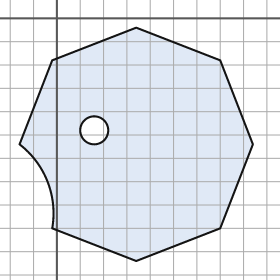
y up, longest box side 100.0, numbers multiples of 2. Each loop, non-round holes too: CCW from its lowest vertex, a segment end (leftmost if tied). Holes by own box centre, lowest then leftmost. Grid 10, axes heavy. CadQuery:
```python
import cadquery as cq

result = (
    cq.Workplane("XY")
    .moveTo(34.0, -104.0)
    .lineTo(70.0, -90.0)
    .lineTo(84.0, -54.0)
    .lineTo(70.0, -18.0)
    .lineTo(34.0, -4.0)
    .lineTo(-2.0, -18.0)
    .lineTo(-16.0, -54.0)
    .threePointArc((-4.0, -70.0), (-2.0, -90.0))
    .close()
    .moveTo(16.0, -48.0)
    .circle(6.0)
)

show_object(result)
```